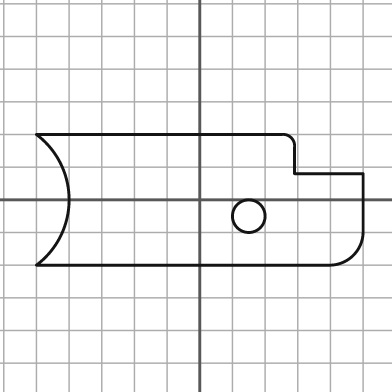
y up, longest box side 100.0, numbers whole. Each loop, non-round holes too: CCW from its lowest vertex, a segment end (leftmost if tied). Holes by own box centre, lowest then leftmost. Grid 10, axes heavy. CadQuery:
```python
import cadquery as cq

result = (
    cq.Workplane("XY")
    .moveTo(-50.0, -20.0)
    .lineTo(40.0, -20.0)
    .threePointArc((47.0, -17.0), (50.0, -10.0))
    .lineTo(50.0, 8.0)
    .lineTo(29.0, 8.0)
    .lineTo(29.0, 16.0)
    .threePointArc((28.0, 19.0), (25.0, 20.0))
    .lineTo(-50.0, 20.0)
    .threePointArc((-40.0, 0.0), (-50.0, -20.0))
    .close()
    .moveTo(15.0, -5.0)
    .circle(5.0)
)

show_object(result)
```